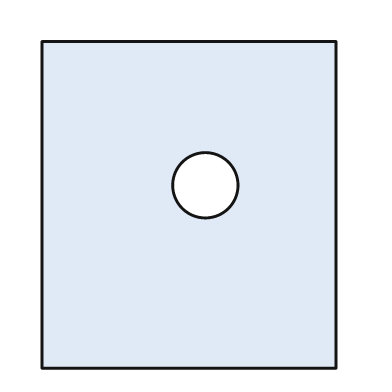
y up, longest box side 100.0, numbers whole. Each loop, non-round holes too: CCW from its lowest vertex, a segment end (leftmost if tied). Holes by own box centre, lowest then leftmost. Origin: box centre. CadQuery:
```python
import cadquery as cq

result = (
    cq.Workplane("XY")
    .moveTo(-45.0, -50.0)
    .lineTo(45.0, -50.0)
    .lineTo(45.0, 50.0)
    .lineTo(-45.0, 50.0)
    .close()
    .moveTo(5.0, 6.0)
    .circle(10.0)
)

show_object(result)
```